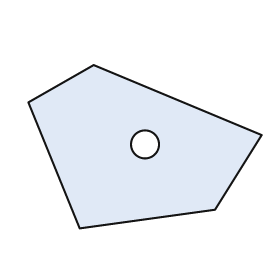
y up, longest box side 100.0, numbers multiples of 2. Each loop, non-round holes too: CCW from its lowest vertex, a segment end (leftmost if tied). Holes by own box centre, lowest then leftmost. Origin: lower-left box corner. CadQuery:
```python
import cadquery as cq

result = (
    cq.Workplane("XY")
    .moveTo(22.0, 0.0)
    .lineTo(80.0, 8.0)
    .lineTo(100.0, 40.0)
    .lineTo(28.0, 70.0)
    .lineTo(0.0, 54.0)
    .close()
    .moveTo(50.0, 36.0)
    .circle(6.0)
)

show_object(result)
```